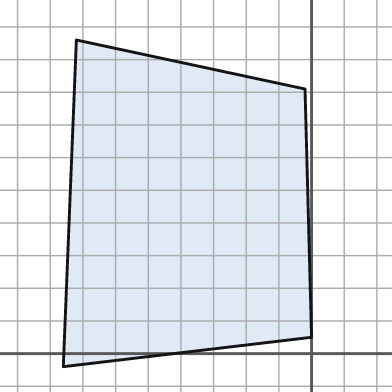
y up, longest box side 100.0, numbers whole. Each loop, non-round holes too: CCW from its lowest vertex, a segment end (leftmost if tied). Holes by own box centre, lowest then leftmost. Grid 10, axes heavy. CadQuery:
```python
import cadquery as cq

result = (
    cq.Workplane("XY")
    .moveTo(-76.0, -4.0)
    .lineTo(0.0, 5.0)
    .lineTo(-2.0, 81.0)
    .lineTo(-72.0, 96.0)
    .close()
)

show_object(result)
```